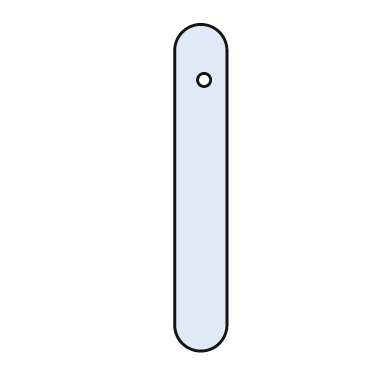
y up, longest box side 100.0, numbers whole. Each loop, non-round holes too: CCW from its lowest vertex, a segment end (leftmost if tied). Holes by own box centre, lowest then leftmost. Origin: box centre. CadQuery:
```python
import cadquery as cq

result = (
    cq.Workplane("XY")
    .moveTo(-8.0, -42.0)
    .threePointArc((0.0, -50.0), (8.0, -42.0))
    .lineTo(8.0, 42.0)
    .threePointArc((0.0, 50.0), (-8.0, 42.0))
    .close()
    .moveTo(1.0, 33.0)
    .circle(2.0)
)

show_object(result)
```